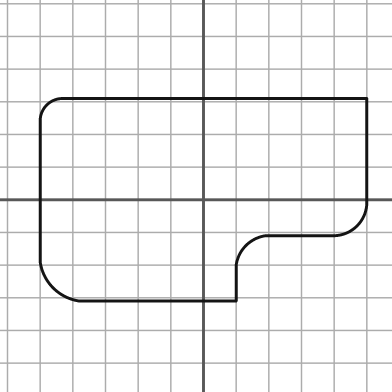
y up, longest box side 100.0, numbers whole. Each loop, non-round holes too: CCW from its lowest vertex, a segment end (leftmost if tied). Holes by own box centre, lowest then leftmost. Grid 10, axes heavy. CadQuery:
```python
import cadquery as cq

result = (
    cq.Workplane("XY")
    .moveTo(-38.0, -31.0)
    .lineTo(10.0, -31.0)
    .lineTo(10.0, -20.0)
    .threePointArc((13.0, -14.0), (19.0, -11.0))
    .lineTo(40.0, -11.0)
    .threePointArc((47.0, -8.0), (50.0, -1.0))
    .lineTo(50.0, 31.0)
    .lineTo(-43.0, 31.0)
    .threePointArc((-48.0, 29.0), (-50.0, 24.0))
    .lineTo(-50.0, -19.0)
    .threePointArc((-46.0, -27.0), (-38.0, -31.0))
    .close()
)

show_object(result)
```